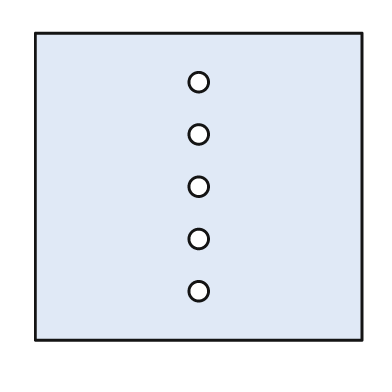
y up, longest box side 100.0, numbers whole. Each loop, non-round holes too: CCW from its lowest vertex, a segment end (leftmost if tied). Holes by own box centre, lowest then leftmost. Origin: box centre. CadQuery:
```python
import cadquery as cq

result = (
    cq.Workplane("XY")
    .moveTo(-50.0, -47.0)
    .lineTo(50.0, -47.0)
    .lineTo(50.0, 47.0)
    .lineTo(-50.0, 47.0)
    .close()
    .moveTo(0.0, -32.0)
    .circle(3.0)
    .moveTo(0.0, -16.0)
    .circle(3.0)
    .moveTo(0.0, 0.0)
    .circle(3.0)
    .moveTo(0.0, 16.0)
    .circle(3.0)
    .moveTo(0.0, 32.0)
    .circle(3.0)
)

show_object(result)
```